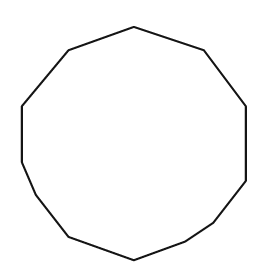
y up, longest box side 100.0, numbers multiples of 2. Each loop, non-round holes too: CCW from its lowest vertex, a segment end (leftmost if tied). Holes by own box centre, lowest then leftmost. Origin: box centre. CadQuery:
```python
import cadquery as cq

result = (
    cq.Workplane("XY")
    .moveTo(0.0, -50.0)
    .lineTo(22.0, -42.0)
    .lineTo(34.0, -34.0)
    .lineTo(48.0, -16.0)
    .lineTo(48.0, 16.0)
    .lineTo(30.0, 40.0)
    .lineTo(0.0, 50.0)
    .lineTo(-28.0, 40.0)
    .lineTo(-48.0, 16.0)
    .lineTo(-48.0, -8.0)
    .lineTo(-42.0, -22.0)
    .lineTo(-28.0, -40.0)
    .close()
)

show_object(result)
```